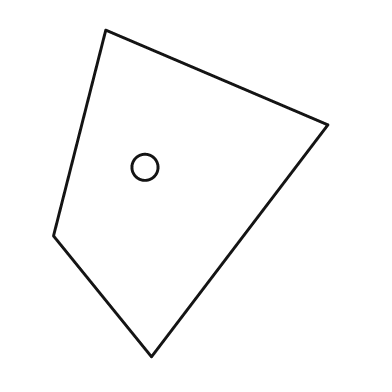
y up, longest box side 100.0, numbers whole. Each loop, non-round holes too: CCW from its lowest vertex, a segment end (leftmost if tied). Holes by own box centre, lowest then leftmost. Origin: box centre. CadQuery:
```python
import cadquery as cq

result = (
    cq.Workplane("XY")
    .moveTo(-12.0, -50.0)
    .lineTo(42.0, 21.0)
    .lineTo(-26.0, 50.0)
    .lineTo(-42.0, -13.0)
    .close()
    .moveTo(-14.0, 8.0)
    .circle(4.0)
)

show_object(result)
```